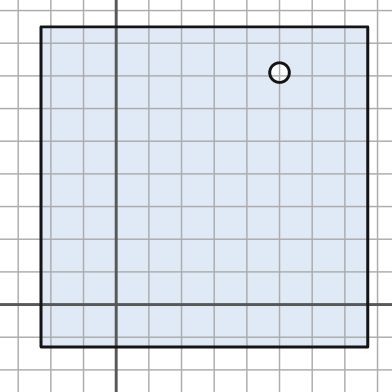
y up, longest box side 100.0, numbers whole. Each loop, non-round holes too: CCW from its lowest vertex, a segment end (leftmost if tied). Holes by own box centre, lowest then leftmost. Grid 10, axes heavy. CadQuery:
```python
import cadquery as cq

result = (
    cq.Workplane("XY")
    .moveTo(-23.0, -13.0)
    .lineTo(77.0, -13.0)
    .lineTo(77.0, 85.0)
    .lineTo(-23.0, 85.0)
    .close()
    .moveTo(50.0, 71.0)
    .circle(3.0)
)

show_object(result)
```